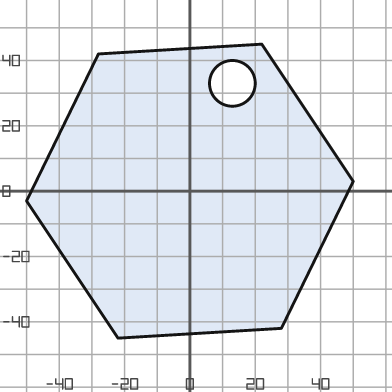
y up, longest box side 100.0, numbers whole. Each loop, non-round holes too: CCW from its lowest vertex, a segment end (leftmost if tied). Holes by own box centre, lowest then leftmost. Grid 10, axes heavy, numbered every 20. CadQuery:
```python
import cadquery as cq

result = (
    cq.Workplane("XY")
    .moveTo(-22.0, -45.0)
    .lineTo(28.0, -42.0)
    .lineTo(50.0, 3.0)
    .lineTo(22.0, 45.0)
    .lineTo(-28.0, 42.0)
    .lineTo(-50.0, -3.0)
    .close()
    .moveTo(13.0, 33.0)
    .circle(7.0)
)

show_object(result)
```